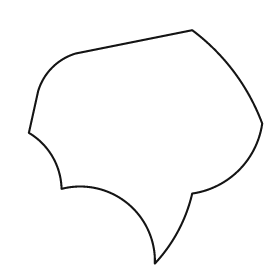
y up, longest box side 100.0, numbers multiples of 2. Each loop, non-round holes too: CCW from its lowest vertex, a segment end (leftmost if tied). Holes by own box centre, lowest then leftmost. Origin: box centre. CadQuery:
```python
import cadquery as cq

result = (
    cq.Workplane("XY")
    .moveTo(4.0, -50.0)
    .threePointArc((14.0, -36.0), (20.0, -20.0))
    .threePointArc((40.0, -10.0), (50.0, 10.0))
    .threePointArc((38.0, 32.0), (20.0, 50.0))
    .lineTo(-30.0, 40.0)
    .threePointArc((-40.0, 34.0), (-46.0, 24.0))
    .lineTo(-50.0, 6.0)
    .threePointArc((-40.0, -4.0), (-36.0, -18.0))
    .threePointArc((-8.0, -24.0), (4.0, -50.0))
    .close()
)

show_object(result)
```